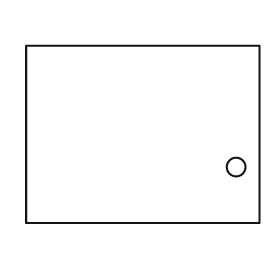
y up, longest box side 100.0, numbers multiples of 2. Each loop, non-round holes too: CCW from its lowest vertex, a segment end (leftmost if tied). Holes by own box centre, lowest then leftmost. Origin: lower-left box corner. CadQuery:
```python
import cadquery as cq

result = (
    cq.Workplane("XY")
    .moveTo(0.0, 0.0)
    .lineTo(100.0, 0.0)
    .lineTo(100.0, 76.0)
    .lineTo(0.0, 76.0)
    .close()
    .moveTo(90.0, 24.0)
    .circle(4.0)
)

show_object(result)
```